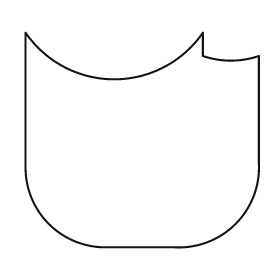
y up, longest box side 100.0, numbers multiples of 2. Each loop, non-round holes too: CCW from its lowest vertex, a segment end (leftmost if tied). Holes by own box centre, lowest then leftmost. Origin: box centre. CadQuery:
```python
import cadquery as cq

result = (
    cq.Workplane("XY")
    .moveTo(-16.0, -46.0)
    .lineTo(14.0, -46.0)
    .threePointArc((40.0, -36.0), (50.0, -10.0))
    .lineTo(50.0, 36.0)
    .threePointArc((38.0, 34.0), (26.0, 36.0))
    .lineTo(26.0, 46.0)
    .threePointArc((-12.0, 26.0), (-50.0, 46.0))
    .lineTo(-50.0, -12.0)
    .threePointArc((-40.0, -36.0), (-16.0, -46.0))
    .close()
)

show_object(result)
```